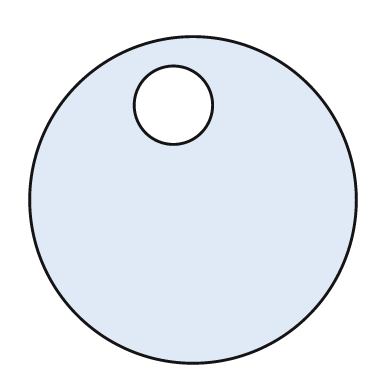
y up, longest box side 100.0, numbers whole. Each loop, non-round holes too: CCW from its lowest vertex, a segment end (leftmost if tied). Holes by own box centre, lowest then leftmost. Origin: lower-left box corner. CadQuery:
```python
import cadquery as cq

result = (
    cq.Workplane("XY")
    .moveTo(50.0, 50.0)
    .circle(50.0)
    .moveTo(44.0, 79.0)
    .circle(12.0)
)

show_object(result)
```